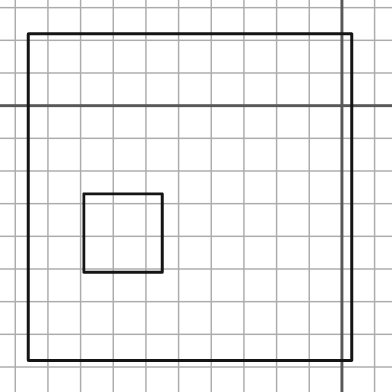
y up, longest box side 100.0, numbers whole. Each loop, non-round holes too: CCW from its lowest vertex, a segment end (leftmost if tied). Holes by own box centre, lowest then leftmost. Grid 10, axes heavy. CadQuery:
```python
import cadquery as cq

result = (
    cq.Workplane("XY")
    .moveTo(-96.0, -78.0)
    .lineTo(3.0, -78.0)
    .lineTo(3.0, 22.0)
    .lineTo(-96.0, 22.0)
    .close()
    .moveTo(-79.0, -51.0)
    .lineTo(-55.0, -51.0)
    .lineTo(-55.0, -27.0)
    .lineTo(-79.0, -27.0)
    .close()
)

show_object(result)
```